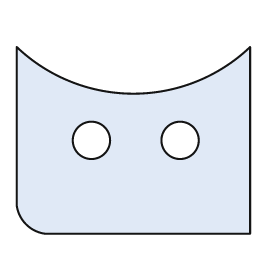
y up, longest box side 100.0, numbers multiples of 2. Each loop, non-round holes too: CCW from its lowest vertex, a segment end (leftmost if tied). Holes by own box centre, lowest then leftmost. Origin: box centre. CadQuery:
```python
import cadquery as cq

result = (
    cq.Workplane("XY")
    .moveTo(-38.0, -40.0)
    .lineTo(50.0, -40.0)
    .lineTo(50.0, 40.0)
    .threePointArc((0.0, 20.0), (-50.0, 40.0))
    .lineTo(-50.0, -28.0)
    .threePointArc((-46.0, -36.0), (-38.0, -40.0))
    .close()
    .moveTo(-18.0, 0.0)
    .circle(8.0)
    .moveTo(20.0, 0.0)
    .circle(8.0)
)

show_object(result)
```